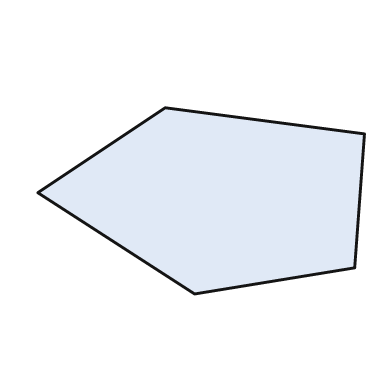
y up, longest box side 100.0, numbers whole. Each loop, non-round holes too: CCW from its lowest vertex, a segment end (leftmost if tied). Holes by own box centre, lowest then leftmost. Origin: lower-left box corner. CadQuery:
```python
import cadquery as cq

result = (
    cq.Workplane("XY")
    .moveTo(48.0, 0.0)
    .lineTo(97.0, 8.0)
    .lineTo(100.0, 49.0)
    .lineTo(39.0, 57.0)
    .lineTo(0.0, 31.0)
    .close()
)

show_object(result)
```